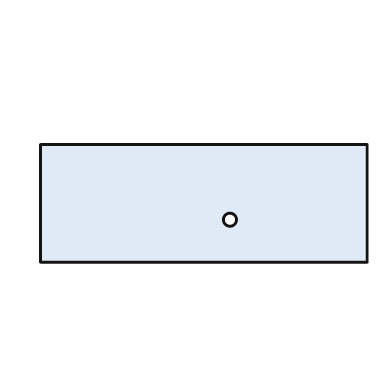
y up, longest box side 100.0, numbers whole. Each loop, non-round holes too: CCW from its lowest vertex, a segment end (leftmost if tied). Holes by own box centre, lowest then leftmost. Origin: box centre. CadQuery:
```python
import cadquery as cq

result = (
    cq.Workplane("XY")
    .moveTo(-50.0, -18.0)
    .lineTo(50.0, -18.0)
    .lineTo(50.0, 18.0)
    .lineTo(-50.0, 18.0)
    .close()
    .moveTo(8.0, -5.0)
    .circle(2.0)
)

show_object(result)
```